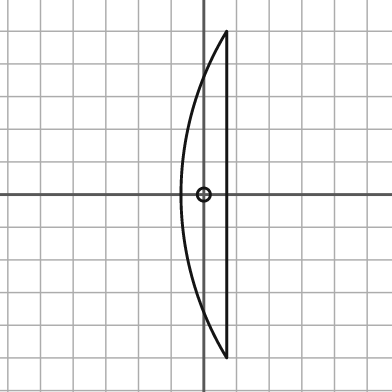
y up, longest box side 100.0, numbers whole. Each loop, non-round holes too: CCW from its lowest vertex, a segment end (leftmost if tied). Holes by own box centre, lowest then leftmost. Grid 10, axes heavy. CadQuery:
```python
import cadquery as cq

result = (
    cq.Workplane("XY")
    .moveTo(7.0, -50.0)
    .lineTo(7.0, 50.0)
    .threePointArc((-7.0, 0.0), (7.0, -50.0))
    .close()
    .moveTo(0.0, 0.0)
    .circle(2.0)
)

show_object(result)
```